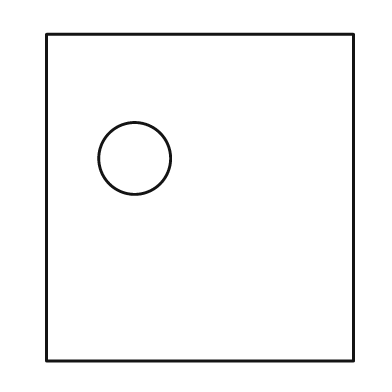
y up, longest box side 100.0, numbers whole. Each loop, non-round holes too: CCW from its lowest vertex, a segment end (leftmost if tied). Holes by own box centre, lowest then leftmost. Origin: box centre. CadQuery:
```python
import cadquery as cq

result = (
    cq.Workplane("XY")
    .moveTo(-47.0, -50.0)
    .lineTo(47.0, -50.0)
    .lineTo(47.0, 50.0)
    .lineTo(-47.0, 50.0)
    .close()
    .moveTo(-20.0, 12.0)
    .circle(11.0)
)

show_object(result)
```